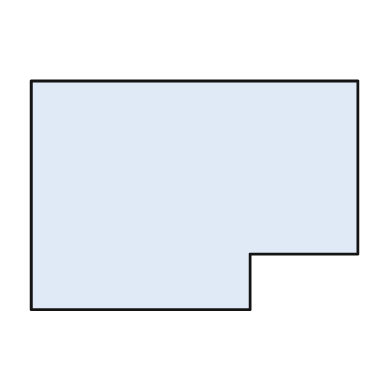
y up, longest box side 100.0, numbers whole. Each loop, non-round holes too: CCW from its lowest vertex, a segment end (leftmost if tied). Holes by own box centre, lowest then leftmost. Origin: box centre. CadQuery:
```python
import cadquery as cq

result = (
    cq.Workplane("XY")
    .moveTo(-50.0, -35.0)
    .lineTo(17.0, -35.0)
    .lineTo(17.0, -18.0)
    .lineTo(50.0, -18.0)
    .lineTo(50.0, 35.0)
    .lineTo(-50.0, 35.0)
    .close()
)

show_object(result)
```